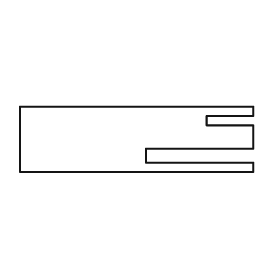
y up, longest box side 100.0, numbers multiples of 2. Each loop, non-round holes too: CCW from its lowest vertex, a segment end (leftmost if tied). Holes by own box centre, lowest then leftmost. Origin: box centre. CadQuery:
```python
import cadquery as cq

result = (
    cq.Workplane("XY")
    .moveTo(-50.0, -14.0)
    .lineTo(50.0, -14.0)
    .lineTo(50.0, -10.0)
    .lineTo(4.0, -10.0)
    .lineTo(4.0, -4.0)
    .lineTo(50.0, -4.0)
    .lineTo(50.0, 6.0)
    .lineTo(30.0, 6.0)
    .lineTo(30.0, 10.0)
    .lineTo(50.0, 10.0)
    .lineTo(50.0, 14.0)
    .lineTo(-50.0, 14.0)
    .close()
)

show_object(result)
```